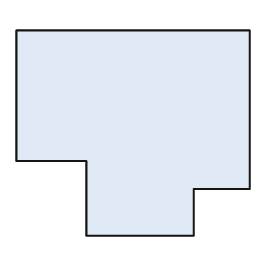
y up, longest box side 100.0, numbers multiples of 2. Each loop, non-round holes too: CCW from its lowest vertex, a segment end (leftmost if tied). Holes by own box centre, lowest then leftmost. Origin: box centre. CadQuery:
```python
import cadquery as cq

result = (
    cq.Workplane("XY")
    .moveTo(-20.0, -44.0)
    .lineTo(26.0, -44.0)
    .lineTo(26.0, -24.0)
    .lineTo(50.0, -24.0)
    .lineTo(50.0, 44.0)
    .lineTo(-50.0, 44.0)
    .lineTo(-50.0, -12.0)
    .lineTo(-20.0, -12.0)
    .close()
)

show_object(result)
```